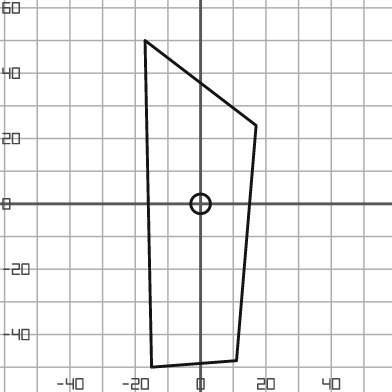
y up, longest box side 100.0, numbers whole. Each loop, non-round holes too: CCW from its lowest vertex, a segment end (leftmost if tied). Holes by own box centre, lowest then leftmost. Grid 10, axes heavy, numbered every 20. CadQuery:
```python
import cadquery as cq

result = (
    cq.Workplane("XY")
    .moveTo(-15.0, -50.0)
    .lineTo(11.0, -48.0)
    .lineTo(17.0, 24.0)
    .lineTo(-17.0, 50.0)
    .close()
    .moveTo(0.0, 0.0)
    .circle(3.0)
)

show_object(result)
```